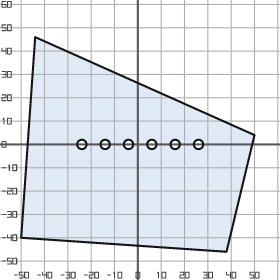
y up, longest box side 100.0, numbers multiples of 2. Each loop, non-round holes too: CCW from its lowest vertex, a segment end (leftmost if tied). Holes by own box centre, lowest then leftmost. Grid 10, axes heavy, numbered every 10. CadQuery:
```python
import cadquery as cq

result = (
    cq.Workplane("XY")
    .moveTo(38.0, -46.0)
    .lineTo(50.0, 4.0)
    .lineTo(-44.0, 46.0)
    .lineTo(-50.0, -40.0)
    .close()
    .moveTo(-24.0, 0.0)
    .circle(2.0)
    .moveTo(-14.0, 0.0)
    .circle(2.0)
    .moveTo(-4.0, 0.0)
    .circle(2.0)
    .moveTo(6.0, 0.0)
    .circle(2.0)
    .moveTo(16.0, 0.0)
    .circle(2.0)
    .moveTo(26.0, 0.0)
    .circle(2.0)
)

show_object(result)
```